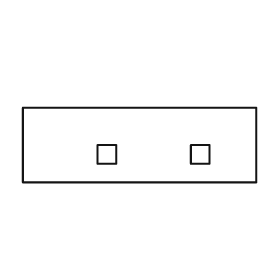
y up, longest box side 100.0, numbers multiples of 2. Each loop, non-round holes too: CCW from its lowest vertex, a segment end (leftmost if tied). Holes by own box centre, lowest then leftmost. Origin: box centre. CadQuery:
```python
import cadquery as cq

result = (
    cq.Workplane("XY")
    .moveTo(-50.0, -16.0)
    .lineTo(50.0, -16.0)
    .lineTo(50.0, 16.0)
    .lineTo(-50.0, 16.0)
    .close()
    .moveTo(-18.0, -8.0)
    .lineTo(-10.0, -8.0)
    .lineTo(-10.0, 0.0)
    .lineTo(-18.0, 0.0)
    .close()
    .moveTo(22.0, -8.0)
    .lineTo(30.0, -8.0)
    .lineTo(30.0, 0.0)
    .lineTo(22.0, 0.0)
    .close()
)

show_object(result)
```